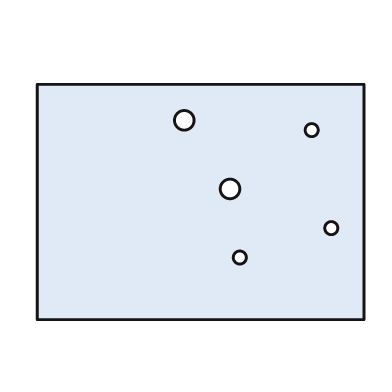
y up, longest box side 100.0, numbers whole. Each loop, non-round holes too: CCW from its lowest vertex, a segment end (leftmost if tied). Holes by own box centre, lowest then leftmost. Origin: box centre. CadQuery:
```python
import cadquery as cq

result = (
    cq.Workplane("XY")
    .moveTo(-50.0, -36.0)
    .lineTo(50.0, -36.0)
    .lineTo(50.0, 36.0)
    .lineTo(-50.0, 36.0)
    .close()
    .moveTo(12.0, -17.0)
    .circle(2.0)
    .moveTo(40.0, -8.0)
    .circle(2.0)
    .moveTo(9.0, 4.0)
    .circle(3.0)
    .moveTo(34.0, 22.0)
    .circle(2.0)
    .moveTo(-5.0, 25.0)
    .circle(3.0)
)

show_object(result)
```